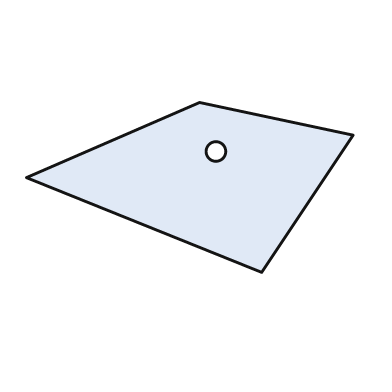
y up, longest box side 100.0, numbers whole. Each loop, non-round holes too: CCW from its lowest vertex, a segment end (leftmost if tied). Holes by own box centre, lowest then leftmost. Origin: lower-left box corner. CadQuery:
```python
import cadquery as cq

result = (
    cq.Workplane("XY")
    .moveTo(72.0, 0.0)
    .lineTo(100.0, 42.0)
    .lineTo(53.0, 52.0)
    .lineTo(0.0, 29.0)
    .close()
    .moveTo(58.0, 37.0)
    .circle(3.0)
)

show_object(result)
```